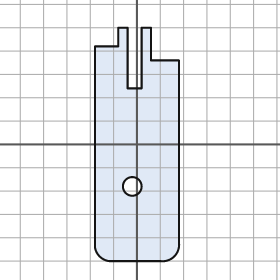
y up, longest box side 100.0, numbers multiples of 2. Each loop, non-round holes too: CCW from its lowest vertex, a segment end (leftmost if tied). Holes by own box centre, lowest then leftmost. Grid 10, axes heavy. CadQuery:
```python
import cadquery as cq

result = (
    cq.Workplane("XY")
    .moveTo(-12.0, -50.0)
    .lineTo(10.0, -50.0)
    .threePointArc((16.0, -48.0), (18.0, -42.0))
    .lineTo(18.0, 36.0)
    .lineTo(6.0, 36.0)
    .lineTo(6.0, 50.0)
    .lineTo(2.0, 50.0)
    .lineTo(2.0, 24.0)
    .lineTo(-4.0, 24.0)
    .lineTo(-4.0, 50.0)
    .lineTo(-8.0, 50.0)
    .lineTo(-8.0, 42.0)
    .lineTo(-18.0, 42.0)
    .lineTo(-18.0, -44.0)
    .threePointArc((-16.0, -48.0), (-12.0, -50.0))
    .close()
    .moveTo(-2.0, -18.0)
    .circle(4.0)
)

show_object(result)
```